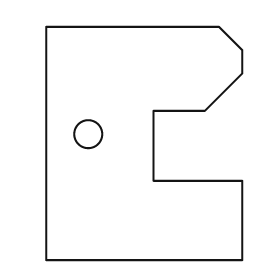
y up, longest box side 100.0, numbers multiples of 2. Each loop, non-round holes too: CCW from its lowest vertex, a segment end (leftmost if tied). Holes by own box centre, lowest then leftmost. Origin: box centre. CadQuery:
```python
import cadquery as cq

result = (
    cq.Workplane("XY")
    .moveTo(-42.0, -50.0)
    .lineTo(42.0, -50.0)
    .lineTo(42.0, -16.0)
    .lineTo(4.0, -16.0)
    .lineTo(4.0, 14.0)
    .lineTo(26.0, 14.0)
    .lineTo(42.0, 30.0)
    .lineTo(42.0, 40.0)
    .lineTo(32.0, 50.0)
    .lineTo(-42.0, 50.0)
    .close()
    .moveTo(-24.0, 4.0)
    .circle(6.0)
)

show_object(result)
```